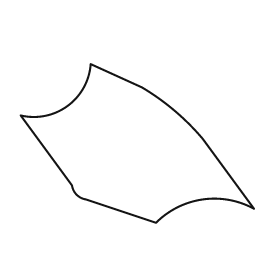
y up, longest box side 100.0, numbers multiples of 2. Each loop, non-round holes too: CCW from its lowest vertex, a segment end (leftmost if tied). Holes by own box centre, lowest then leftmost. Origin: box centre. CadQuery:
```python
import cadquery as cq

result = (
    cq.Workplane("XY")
    .moveTo(8.0, -34.0)
    .threePointArc((28.0, -24.0), (50.0, -28.0))
    .lineTo(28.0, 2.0)
    .threePointArc((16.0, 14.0), (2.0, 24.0))
    .lineTo(-20.0, 34.0)
    .threePointArc((-30.0, 16.0), (-50.0, 12.0))
    .lineTo(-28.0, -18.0)
    .threePointArc((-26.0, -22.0), (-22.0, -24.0))
    .close()
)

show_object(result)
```